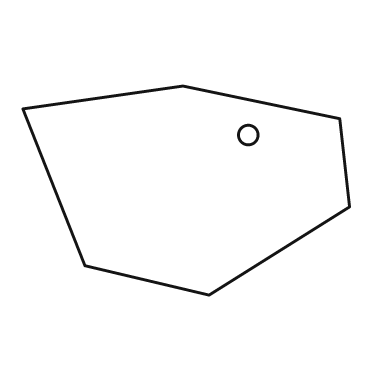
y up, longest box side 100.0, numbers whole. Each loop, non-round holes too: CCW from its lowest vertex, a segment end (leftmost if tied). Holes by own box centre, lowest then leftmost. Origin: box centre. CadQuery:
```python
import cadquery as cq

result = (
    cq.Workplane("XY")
    .moveTo(7.0, -32.0)
    .lineTo(50.0, -5.0)
    .lineTo(47.0, 22.0)
    .lineTo(-1.0, 32.0)
    .lineTo(-50.0, 25.0)
    .lineTo(-31.0, -23.0)
    .close()
    .moveTo(19.0, 17.0)
    .circle(3.0)
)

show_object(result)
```